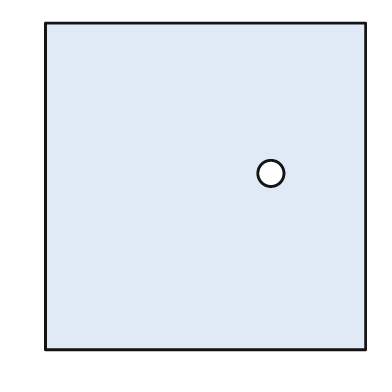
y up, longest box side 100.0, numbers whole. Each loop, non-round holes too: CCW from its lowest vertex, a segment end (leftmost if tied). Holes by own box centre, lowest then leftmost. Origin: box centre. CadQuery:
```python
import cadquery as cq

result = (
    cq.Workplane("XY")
    .moveTo(-49.0, -50.0)
    .lineTo(49.0, -50.0)
    .lineTo(49.0, 50.0)
    .lineTo(-49.0, 50.0)
    .close()
    .moveTo(20.0, 4.0)
    .circle(4.0)
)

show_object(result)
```